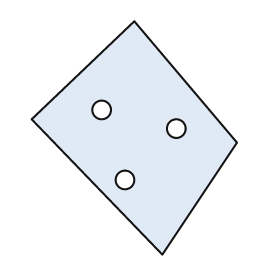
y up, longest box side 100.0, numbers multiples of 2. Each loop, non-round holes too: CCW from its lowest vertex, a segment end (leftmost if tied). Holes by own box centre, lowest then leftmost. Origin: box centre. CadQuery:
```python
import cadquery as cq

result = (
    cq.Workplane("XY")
    .moveTo(12.0, -50.0)
    .lineTo(44.0, -2.0)
    .lineTo(0.0, 50.0)
    .lineTo(-44.0, 8.0)
    .close()
    .moveTo(-4.0, -18.0)
    .circle(4.0)
    .moveTo(18.0, 4.0)
    .circle(4.0)
    .moveTo(-14.0, 12.0)
    .circle(4.0)
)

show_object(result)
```